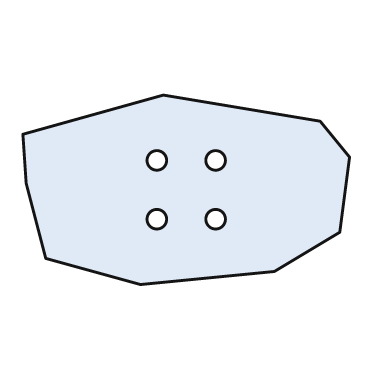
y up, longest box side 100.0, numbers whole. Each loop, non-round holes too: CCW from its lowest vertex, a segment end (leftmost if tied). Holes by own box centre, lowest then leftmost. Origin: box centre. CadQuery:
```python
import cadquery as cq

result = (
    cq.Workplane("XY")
    .moveTo(-14.0, -29.0)
    .lineTo(27.0, -25.0)
    .lineTo(47.0, -13.0)
    .lineTo(50.0, 10.0)
    .lineTo(41.0, 21.0)
    .lineTo(-7.0, 29.0)
    .lineTo(-50.0, 17.0)
    .lineTo(-49.0, 2.0)
    .lineTo(-43.0, -21.0)
    .close()
    .moveTo(-9.0, -9.0)
    .circle(3.0)
    .moveTo(9.0, -9.0)
    .circle(3.0)
    .moveTo(-9.0, 9.0)
    .circle(3.0)
    .moveTo(9.0, 9.0)
    .circle(3.0)
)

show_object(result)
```